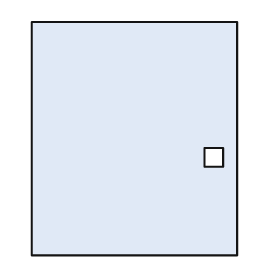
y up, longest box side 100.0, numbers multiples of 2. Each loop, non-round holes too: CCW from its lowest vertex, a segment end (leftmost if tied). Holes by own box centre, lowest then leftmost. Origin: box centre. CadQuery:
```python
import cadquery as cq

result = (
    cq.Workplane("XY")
    .moveTo(-44.0, -50.0)
    .lineTo(44.0, -50.0)
    .lineTo(44.0, 50.0)
    .lineTo(-44.0, 50.0)
    .close()
    .moveTo(30.0, -12.0)
    .lineTo(38.0, -12.0)
    .lineTo(38.0, -4.0)
    .lineTo(30.0, -4.0)
    .close()
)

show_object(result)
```